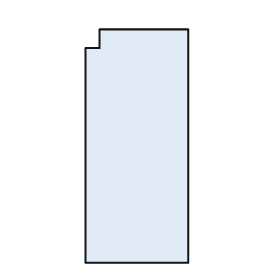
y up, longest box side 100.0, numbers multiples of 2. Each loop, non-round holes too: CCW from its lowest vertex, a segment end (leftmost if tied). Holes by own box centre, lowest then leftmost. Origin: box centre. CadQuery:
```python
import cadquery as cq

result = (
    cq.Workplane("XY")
    .moveTo(-22.0, -50.0)
    .lineTo(22.0, -50.0)
    .lineTo(22.0, 50.0)
    .lineTo(-16.0, 50.0)
    .lineTo(-16.0, 42.0)
    .lineTo(-22.0, 42.0)
    .close()
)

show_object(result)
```